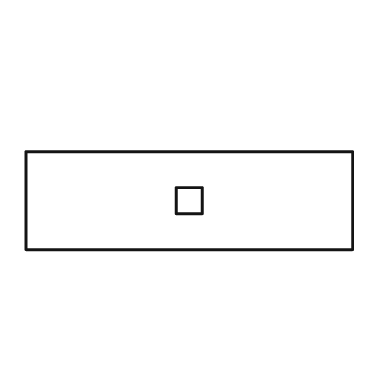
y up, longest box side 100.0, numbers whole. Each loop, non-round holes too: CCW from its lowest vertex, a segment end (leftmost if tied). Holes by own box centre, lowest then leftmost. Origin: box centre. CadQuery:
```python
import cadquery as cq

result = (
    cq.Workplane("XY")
    .moveTo(-50.0, -15.0)
    .lineTo(50.0, -15.0)
    .lineTo(50.0, 15.0)
    .lineTo(-50.0, 15.0)
    .close()
    .moveTo(-4.0, -4.0)
    .lineTo(4.0, -4.0)
    .lineTo(4.0, 4.0)
    .lineTo(-4.0, 4.0)
    .close()
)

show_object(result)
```